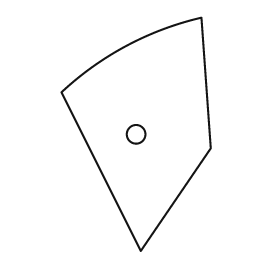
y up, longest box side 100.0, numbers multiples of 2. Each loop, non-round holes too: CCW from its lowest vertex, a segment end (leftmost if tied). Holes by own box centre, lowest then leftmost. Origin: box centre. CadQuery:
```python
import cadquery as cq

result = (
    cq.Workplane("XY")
    .moveTo(2.0, -50.0)
    .lineTo(32.0, -6.0)
    .lineTo(28.0, 50.0)
    .threePointArc((-4.0, 38.0), (-32.0, 18.0))
    .close()
    .moveTo(0.0, 0.0)
    .circle(4.0)
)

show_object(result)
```